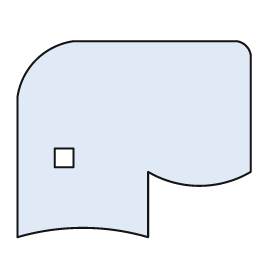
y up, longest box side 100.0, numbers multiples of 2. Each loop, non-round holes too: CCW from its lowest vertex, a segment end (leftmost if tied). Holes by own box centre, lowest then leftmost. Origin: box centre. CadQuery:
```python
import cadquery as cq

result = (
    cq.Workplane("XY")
    .moveTo(-50.0, -42.0)
    .threePointArc((-22.0, -38.0), (6.0, -42.0))
    .lineTo(6.0, -14.0)
    .threePointArc((28.0, -20.0), (50.0, -14.0))
    .lineTo(50.0, 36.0)
    .threePointArc((48.0, 40.0), (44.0, 42.0))
    .lineTo(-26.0, 42.0)
    .threePointArc((-42.0, 34.0), (-50.0, 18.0))
    .close()
    .moveTo(-34.0, -12.0)
    .lineTo(-26.0, -12.0)
    .lineTo(-26.0, -4.0)
    .lineTo(-34.0, -4.0)
    .close()
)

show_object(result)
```